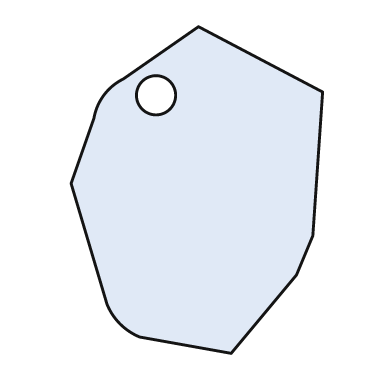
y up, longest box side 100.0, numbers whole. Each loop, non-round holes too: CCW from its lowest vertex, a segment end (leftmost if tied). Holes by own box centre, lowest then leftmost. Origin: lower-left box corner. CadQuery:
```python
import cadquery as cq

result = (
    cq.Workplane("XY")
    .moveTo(49.0, 0.0)
    .lineTo(69.0, 24.0)
    .lineTo(74.0, 36.0)
    .lineTo(77.0, 80.0)
    .lineTo(39.0, 100.0)
    .lineTo(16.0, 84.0)
    .threePointArc((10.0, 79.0), (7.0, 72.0))
    .lineTo(0.0, 52.0)
    .lineTo(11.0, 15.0)
    .threePointArc((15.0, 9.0), (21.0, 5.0))
    .close()
    .moveTo(26.0, 79.0)
    .circle(6.0)
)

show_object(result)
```